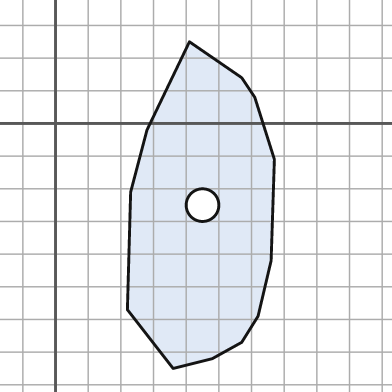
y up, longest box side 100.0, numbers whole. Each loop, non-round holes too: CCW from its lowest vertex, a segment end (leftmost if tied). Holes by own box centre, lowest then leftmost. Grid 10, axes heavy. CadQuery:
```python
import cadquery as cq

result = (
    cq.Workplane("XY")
    .moveTo(36.0, -75.0)
    .lineTo(48.0, -72.0)
    .lineTo(57.0, -67.0)
    .lineTo(62.0, -59.0)
    .lineTo(66.0, -42.0)
    .lineTo(67.0, -11.0)
    .lineTo(61.0, 8.0)
    .lineTo(57.0, 14.0)
    .lineTo(41.0, 25.0)
    .lineTo(28.0, -2.0)
    .lineTo(23.0, -21.0)
    .lineTo(22.0, -57.0)
    .close()
    .moveTo(45.0, -25.0)
    .circle(5.0)
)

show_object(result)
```